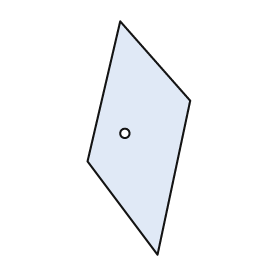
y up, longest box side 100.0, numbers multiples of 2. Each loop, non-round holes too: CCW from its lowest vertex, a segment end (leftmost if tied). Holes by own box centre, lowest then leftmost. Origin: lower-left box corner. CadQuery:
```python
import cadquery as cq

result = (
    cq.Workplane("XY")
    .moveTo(30.0, 0.0)
    .lineTo(44.0, 66.0)
    .lineTo(14.0, 100.0)
    .lineTo(0.0, 40.0)
    .close()
    .moveTo(16.0, 52.0)
    .circle(2.0)
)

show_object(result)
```